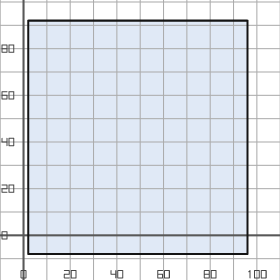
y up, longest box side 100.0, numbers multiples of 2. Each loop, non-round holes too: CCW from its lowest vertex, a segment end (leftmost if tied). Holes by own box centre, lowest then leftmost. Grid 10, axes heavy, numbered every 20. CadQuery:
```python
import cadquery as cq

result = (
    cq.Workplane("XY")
    .moveTo(2.0, -8.0)
    .lineTo(96.0, -8.0)
    .lineTo(96.0, 92.0)
    .lineTo(2.0, 92.0)
    .close()
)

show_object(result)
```